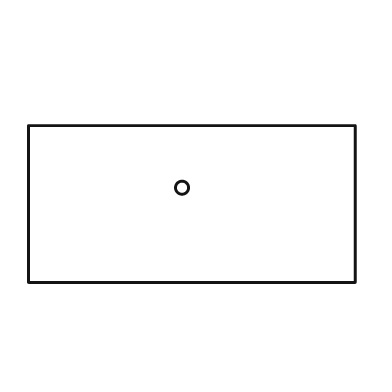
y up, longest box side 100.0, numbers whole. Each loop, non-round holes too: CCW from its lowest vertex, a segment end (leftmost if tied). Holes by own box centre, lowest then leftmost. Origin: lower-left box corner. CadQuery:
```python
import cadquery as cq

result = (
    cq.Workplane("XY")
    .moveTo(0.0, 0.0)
    .lineTo(100.0, 0.0)
    .lineTo(100.0, 48.0)
    .lineTo(0.0, 48.0)
    .close()
    .moveTo(47.0, 29.0)
    .circle(2.0)
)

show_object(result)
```